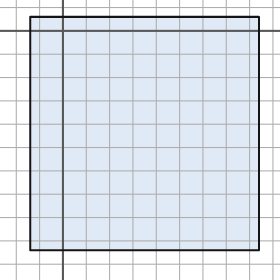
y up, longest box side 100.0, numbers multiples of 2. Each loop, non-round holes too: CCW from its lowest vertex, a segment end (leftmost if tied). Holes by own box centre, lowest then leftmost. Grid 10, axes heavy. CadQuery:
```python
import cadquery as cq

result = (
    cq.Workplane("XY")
    .moveTo(-14.0, -94.0)
    .lineTo(84.0, -94.0)
    .lineTo(84.0, 6.0)
    .lineTo(-14.0, 6.0)
    .close()
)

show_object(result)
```